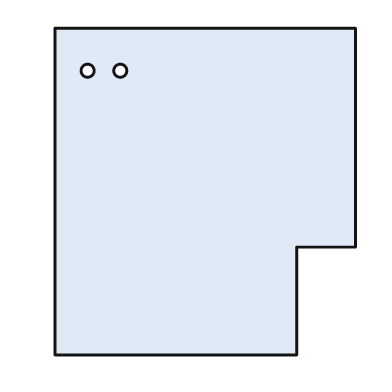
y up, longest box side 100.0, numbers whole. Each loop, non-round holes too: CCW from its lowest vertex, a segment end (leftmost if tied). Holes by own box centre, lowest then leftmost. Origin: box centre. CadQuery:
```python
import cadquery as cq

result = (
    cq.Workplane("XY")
    .moveTo(-46.0, -50.0)
    .lineTo(28.0, -50.0)
    .lineTo(28.0, -17.0)
    .lineTo(46.0, -17.0)
    .lineTo(46.0, 50.0)
    .lineTo(-46.0, 50.0)
    .close()
    .moveTo(-36.0, 37.0)
    .circle(2.0)
    .moveTo(-26.0, 37.0)
    .circle(2.0)
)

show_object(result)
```